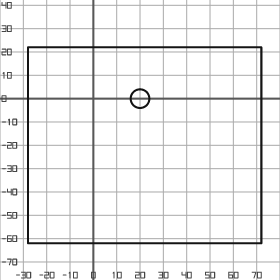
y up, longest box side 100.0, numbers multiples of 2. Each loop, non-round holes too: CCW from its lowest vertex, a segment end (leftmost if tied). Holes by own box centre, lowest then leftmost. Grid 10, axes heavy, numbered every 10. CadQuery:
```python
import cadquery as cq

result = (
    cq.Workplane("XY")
    .moveTo(-28.0, -62.0)
    .lineTo(72.0, -62.0)
    .lineTo(72.0, 22.0)
    .lineTo(-28.0, 22.0)
    .close()
    .moveTo(20.0, 0.0)
    .circle(4.0)
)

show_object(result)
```